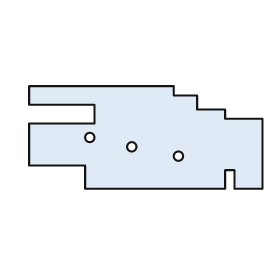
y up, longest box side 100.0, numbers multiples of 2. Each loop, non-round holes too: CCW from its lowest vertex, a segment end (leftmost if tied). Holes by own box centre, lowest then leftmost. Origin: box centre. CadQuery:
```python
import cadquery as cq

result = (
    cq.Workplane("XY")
    .moveTo(-26.0, -22.0)
    .lineTo(34.0, -22.0)
    .lineTo(34.0, -14.0)
    .lineTo(38.0, -14.0)
    .lineTo(38.0, -22.0)
    .lineTo(50.0, -22.0)
    .lineTo(50.0, 8.0)
    .lineTo(34.0, 8.0)
    .lineTo(34.0, 12.0)
    .lineTo(22.0, 12.0)
    .lineTo(22.0, 18.0)
    .lineTo(12.0, 18.0)
    .lineTo(12.0, 22.0)
    .lineTo(-50.0, 22.0)
    .lineTo(-50.0, 14.0)
    .lineTo(-22.0, 14.0)
    .lineTo(-22.0, 6.0)
    .lineTo(-50.0, 6.0)
    .lineTo(-50.0, -12.0)
    .lineTo(-26.0, -12.0)
    .close()
    .moveTo(14.0, -8.0)
    .circle(2.0)
    .moveTo(-6.0, -4.0)
    .circle(2.0)
    .moveTo(-24.0, 0.0)
    .circle(2.0)
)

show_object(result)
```